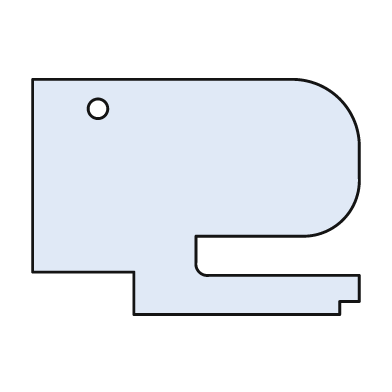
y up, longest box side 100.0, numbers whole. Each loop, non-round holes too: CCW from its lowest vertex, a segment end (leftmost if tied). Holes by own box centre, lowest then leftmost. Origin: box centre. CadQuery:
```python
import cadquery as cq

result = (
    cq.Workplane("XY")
    .moveTo(-19.0, -36.0)
    .lineTo(44.0, -36.0)
    .lineTo(44.0, -32.0)
    .lineTo(50.0, -32.0)
    .lineTo(50.0, -24.0)
    .lineTo(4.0, -24.0)
    .threePointArc((1.0, -23.0), (0.0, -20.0))
    .lineTo(0.0, -12.0)
    .lineTo(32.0, -12.0)
    .threePointArc((45.0, -7.0), (50.0, 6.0))
    .lineTo(50.0, 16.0)
    .threePointArc((44.0, 30.0), (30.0, 36.0))
    .lineTo(-50.0, 36.0)
    .lineTo(-50.0, -23.0)
    .lineTo(-19.0, -23.0)
    .close()
    .moveTo(-30.0, 27.0)
    .circle(3.0)
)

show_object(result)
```